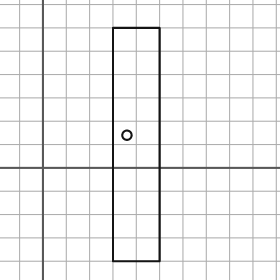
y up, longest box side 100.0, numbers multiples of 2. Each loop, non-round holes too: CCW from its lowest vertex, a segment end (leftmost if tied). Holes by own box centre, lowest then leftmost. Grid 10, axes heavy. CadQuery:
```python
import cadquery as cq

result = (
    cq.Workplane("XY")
    .moveTo(30.0, -40.0)
    .lineTo(50.0, -40.0)
    .lineTo(50.0, 60.0)
    .lineTo(30.0, 60.0)
    .close()
    .moveTo(36.0, 14.0)
    .circle(2.0)
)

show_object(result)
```